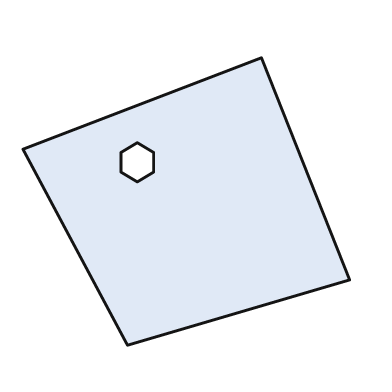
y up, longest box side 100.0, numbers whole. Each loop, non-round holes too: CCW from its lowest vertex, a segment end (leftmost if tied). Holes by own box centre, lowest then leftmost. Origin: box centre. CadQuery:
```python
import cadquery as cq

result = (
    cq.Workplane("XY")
    .moveTo(-18.0, -44.0)
    .lineTo(50.0, -24.0)
    .lineTo(23.0, 44.0)
    .lineTo(-50.0, 16.0)
    .close()
    .moveTo(-15.0, 6.0)
    .lineTo(-10.0, 9.0)
    .lineTo(-10.0, 15.0)
    .lineTo(-15.0, 18.0)
    .lineTo(-20.0, 15.0)
    .lineTo(-20.0, 9.0)
    .close()
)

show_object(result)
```